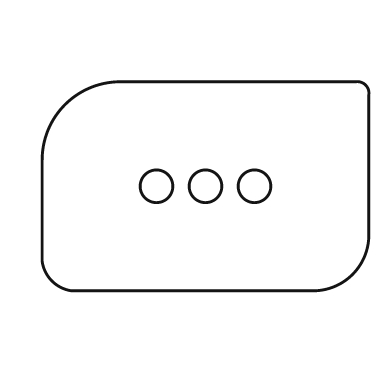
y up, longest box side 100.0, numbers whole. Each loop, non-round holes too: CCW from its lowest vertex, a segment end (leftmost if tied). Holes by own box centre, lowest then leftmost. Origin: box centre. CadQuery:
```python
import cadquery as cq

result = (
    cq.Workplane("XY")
    .moveTo(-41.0, -32.0)
    .lineTo(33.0, -32.0)
    .threePointArc((45.0, -27.0), (50.0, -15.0))
    .lineTo(50.0, 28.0)
    .threePointArc((49.0, 31.0), (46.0, 32.0))
    .lineTo(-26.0, 32.0)
    .threePointArc((-43.0, 25.0), (-50.0, 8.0))
    .lineTo(-50.0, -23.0)
    .threePointArc((-47.0, -29.0), (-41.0, -32.0))
    .close()
    .moveTo(-15.0, 0.0)
    .circle(5.0)
    .moveTo(0.0, 0.0)
    .circle(5.0)
    .moveTo(15.0, 0.0)
    .circle(5.0)
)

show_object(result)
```